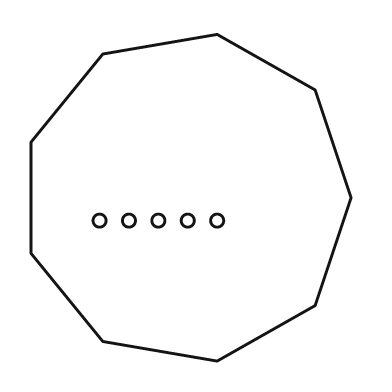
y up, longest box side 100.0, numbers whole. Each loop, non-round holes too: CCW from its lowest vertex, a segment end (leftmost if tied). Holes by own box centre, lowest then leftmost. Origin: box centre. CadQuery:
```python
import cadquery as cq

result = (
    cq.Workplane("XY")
    .moveTo(8.0, -50.0)
    .lineTo(38.0, -33.0)
    .lineTo(49.0, 0.0)
    .lineTo(38.0, 33.0)
    .lineTo(8.0, 50.0)
    .lineTo(-27.0, 44.0)
    .lineTo(-49.0, 17.0)
    .lineTo(-49.0, -17.0)
    .lineTo(-27.0, -44.0)
    .close()
    .moveTo(-28.0, -7.0)
    .circle(2.0)
    .moveTo(-19.0, -7.0)
    .circle(2.0)
    .moveTo(-10.0, -7.0)
    .circle(2.0)
    .moveTo(-1.0, -7.0)
    .circle(2.0)
    .moveTo(8.0, -7.0)
    .circle(2.0)
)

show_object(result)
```